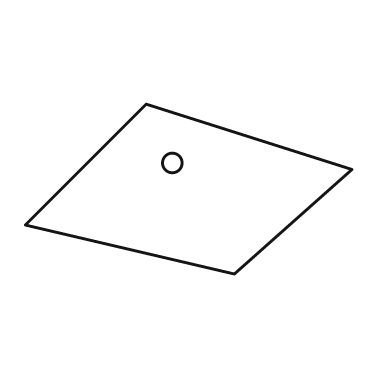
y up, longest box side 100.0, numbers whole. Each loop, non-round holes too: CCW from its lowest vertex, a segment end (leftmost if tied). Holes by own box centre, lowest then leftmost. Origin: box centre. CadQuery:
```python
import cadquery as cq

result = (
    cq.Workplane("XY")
    .moveTo(14.0, -26.0)
    .lineTo(50.0, 6.0)
    .lineTo(-13.0, 26.0)
    .lineTo(-50.0, -11.0)
    .close()
    .moveTo(-5.0, 8.0)
    .circle(3.0)
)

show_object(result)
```